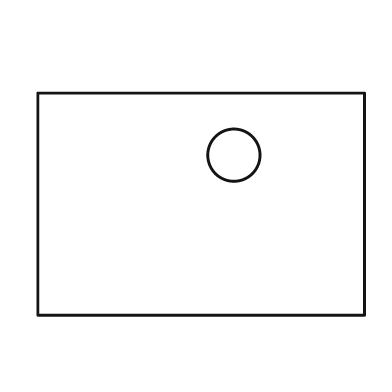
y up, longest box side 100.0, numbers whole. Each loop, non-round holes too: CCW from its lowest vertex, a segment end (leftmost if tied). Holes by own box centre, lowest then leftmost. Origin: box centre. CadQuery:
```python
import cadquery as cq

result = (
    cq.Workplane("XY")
    .moveTo(-50.0, -34.0)
    .lineTo(50.0, -34.0)
    .lineTo(50.0, 34.0)
    .lineTo(-50.0, 34.0)
    .close()
    .moveTo(10.0, 15.0)
    .circle(8.0)
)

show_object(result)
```